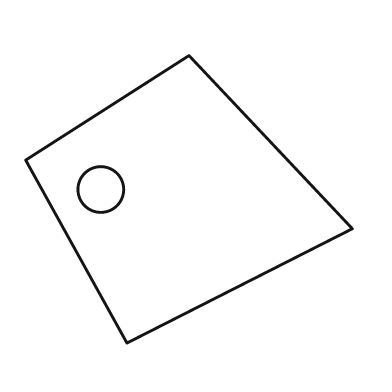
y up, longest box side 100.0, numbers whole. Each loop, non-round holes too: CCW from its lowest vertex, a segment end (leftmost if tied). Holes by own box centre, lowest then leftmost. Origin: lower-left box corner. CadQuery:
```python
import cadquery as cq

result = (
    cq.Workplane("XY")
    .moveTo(31.0, 0.0)
    .lineTo(100.0, 35.0)
    .lineTo(50.0, 88.0)
    .lineTo(0.0, 56.0)
    .close()
    .moveTo(23.0, 47.0)
    .circle(7.0)
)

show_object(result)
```